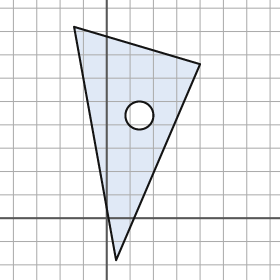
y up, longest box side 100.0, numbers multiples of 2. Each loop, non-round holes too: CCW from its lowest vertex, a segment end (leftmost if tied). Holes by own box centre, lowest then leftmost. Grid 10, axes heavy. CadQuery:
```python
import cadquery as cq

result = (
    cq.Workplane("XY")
    .moveTo(4.0, -18.0)
    .lineTo(40.0, 66.0)
    .lineTo(-14.0, 82.0)
    .close()
    .moveTo(14.0, 44.0)
    .circle(6.0)
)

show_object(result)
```